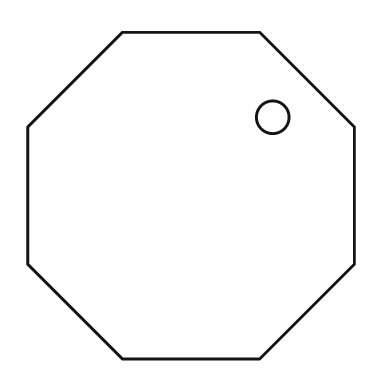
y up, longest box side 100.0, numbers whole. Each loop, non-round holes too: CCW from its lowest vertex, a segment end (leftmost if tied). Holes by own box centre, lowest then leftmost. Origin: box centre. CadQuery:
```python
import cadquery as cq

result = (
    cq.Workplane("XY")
    .moveTo(-21.0, -50.0)
    .lineTo(21.0, -50.0)
    .lineTo(50.0, -21.0)
    .lineTo(50.0, 21.0)
    .lineTo(21.0, 50.0)
    .lineTo(-21.0, 50.0)
    .lineTo(-50.0, 21.0)
    .lineTo(-50.0, -21.0)
    .close()
    .moveTo(25.0, 24.0)
    .circle(5.0)
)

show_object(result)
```